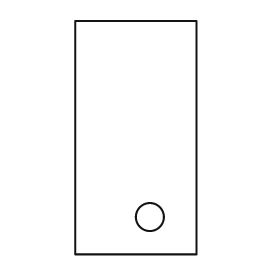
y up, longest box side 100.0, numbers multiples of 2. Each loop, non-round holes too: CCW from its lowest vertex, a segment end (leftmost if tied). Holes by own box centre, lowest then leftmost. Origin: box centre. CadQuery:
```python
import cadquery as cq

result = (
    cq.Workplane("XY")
    .moveTo(-26.0, -50.0)
    .lineTo(26.0, -50.0)
    .lineTo(26.0, 50.0)
    .lineTo(-26.0, 50.0)
    .close()
    .moveTo(6.0, -34.0)
    .circle(6.0)
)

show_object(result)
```